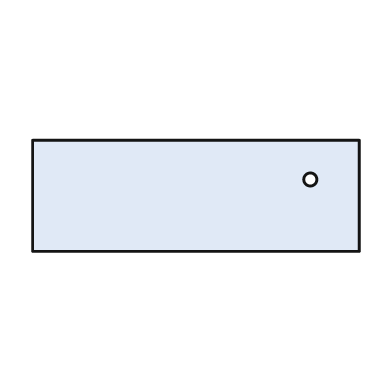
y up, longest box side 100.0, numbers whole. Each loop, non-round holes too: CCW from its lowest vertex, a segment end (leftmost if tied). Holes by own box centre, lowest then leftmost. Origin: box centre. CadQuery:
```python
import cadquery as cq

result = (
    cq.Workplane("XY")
    .moveTo(-50.0, -17.0)
    .lineTo(50.0, -17.0)
    .lineTo(50.0, 17.0)
    .lineTo(-50.0, 17.0)
    .close()
    .moveTo(35.0, 5.0)
    .circle(2.0)
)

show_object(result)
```